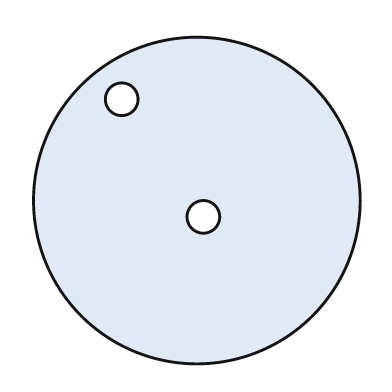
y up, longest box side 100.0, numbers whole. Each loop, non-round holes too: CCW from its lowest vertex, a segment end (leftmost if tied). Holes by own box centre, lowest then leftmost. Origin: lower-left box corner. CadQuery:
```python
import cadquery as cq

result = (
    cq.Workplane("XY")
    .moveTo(50.0, 50.0)
    .circle(50.0)
    .moveTo(52.0, 45.0)
    .circle(5.0)
    .moveTo(27.0, 81.0)
    .circle(5.0)
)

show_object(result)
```